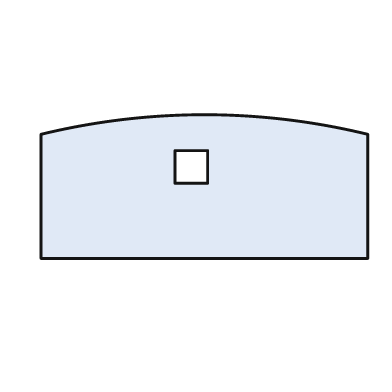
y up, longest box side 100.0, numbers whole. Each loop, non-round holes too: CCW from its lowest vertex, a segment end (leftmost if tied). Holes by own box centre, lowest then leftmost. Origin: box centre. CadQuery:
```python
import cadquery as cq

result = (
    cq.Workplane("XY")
    .moveTo(-50.0, -22.0)
    .lineTo(50.0, -22.0)
    .lineTo(50.0, 16.0)
    .threePointArc((0.0, 22.0), (-50.0, 16.0))
    .close()
    .moveTo(-9.0, 1.0)
    .lineTo(1.0, 1.0)
    .lineTo(1.0, 11.0)
    .lineTo(-9.0, 11.0)
    .close()
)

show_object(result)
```